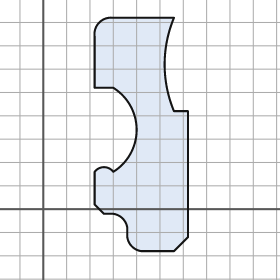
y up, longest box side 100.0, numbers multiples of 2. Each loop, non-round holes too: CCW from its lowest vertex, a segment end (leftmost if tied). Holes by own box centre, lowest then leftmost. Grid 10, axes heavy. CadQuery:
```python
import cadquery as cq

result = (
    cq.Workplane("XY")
    .moveTo(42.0, -18.0)
    .lineTo(56.0, -18.0)
    .lineTo(62.0, -12.0)
    .lineTo(62.0, 42.0)
    .lineTo(56.0, 42.0)
    .threePointArc((52.0, 62.0), (56.0, 82.0))
    .lineTo(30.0, 82.0)
    .threePointArc((24.0, 80.0), (22.0, 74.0))
    .lineTo(22.0, 52.0)
    .lineTo(30.0, 52.0)
    .threePointArc((40.0, 34.0), (30.0, 16.0))
    .threePointArc((26.0, 18.0), (22.0, 16.0))
    .lineTo(22.0, 2.0)
    .lineTo(26.0, -2.0)
    .lineTo(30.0, -2.0)
    .threePointArc((34.0, -4.0), (36.0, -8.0))
    .lineTo(36.0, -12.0)
    .threePointArc((38.0, -16.0), (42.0, -18.0))
    .close()
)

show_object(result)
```